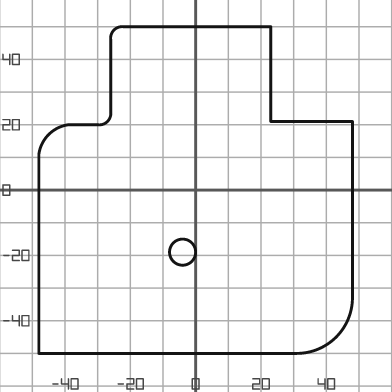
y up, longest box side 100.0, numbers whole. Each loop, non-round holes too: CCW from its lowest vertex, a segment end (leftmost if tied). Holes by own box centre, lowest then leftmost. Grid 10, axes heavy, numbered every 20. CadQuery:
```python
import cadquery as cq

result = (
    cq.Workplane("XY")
    .moveTo(-48.0, -50.0)
    .lineTo(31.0, -50.0)
    .threePointArc((43.0, -45.0), (48.0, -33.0))
    .lineTo(48.0, 21.0)
    .lineTo(23.0, 21.0)
    .lineTo(23.0, 50.0)
    .lineTo(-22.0, 50.0)
    .threePointArc((-25.0, 49.0), (-26.0, 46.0))
    .lineTo(-26.0, 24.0)
    .threePointArc((-27.0, 21.0), (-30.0, 20.0))
    .lineTo(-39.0, 20.0)
    .threePointArc((-45.0, 17.0), (-48.0, 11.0))
    .close()
    .moveTo(-4.0, -19.0)
    .circle(4.0)
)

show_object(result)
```